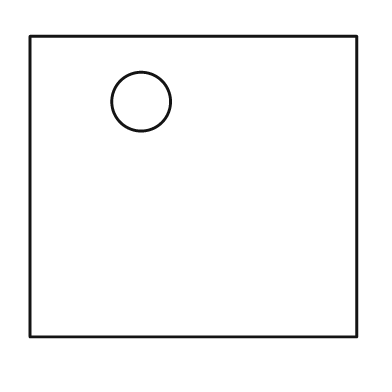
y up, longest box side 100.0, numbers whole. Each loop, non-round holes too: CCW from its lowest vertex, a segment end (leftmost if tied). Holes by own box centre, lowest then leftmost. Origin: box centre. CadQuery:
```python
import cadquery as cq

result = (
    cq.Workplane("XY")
    .moveTo(-50.0, -46.0)
    .lineTo(50.0, -46.0)
    .lineTo(50.0, 46.0)
    .lineTo(-50.0, 46.0)
    .close()
    .moveTo(-16.0, 26.0)
    .circle(9.0)
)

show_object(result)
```